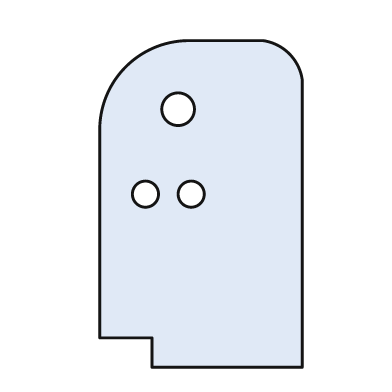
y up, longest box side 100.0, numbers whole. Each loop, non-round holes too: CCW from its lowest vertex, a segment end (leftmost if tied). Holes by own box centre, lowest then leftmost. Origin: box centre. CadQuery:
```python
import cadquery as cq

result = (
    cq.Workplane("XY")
    .moveTo(-15.0, -50.0)
    .lineTo(31.0, -50.0)
    .lineTo(31.0, 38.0)
    .threePointArc((27.0, 46.0), (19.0, 50.0))
    .lineTo(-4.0, 50.0)
    .threePointArc((-23.0, 42.0), (-31.0, 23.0))
    .lineTo(-31.0, -41.0)
    .lineTo(-15.0, -41.0)
    .close()
    .moveTo(-17.0, 3.0)
    .circle(4.0)
    .moveTo(-3.0, 3.0)
    .circle(4.0)
    .moveTo(-7.0, 29.0)
    .circle(5.0)
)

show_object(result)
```